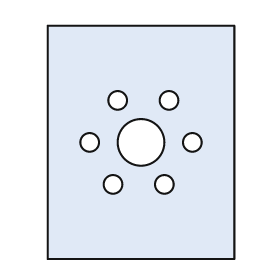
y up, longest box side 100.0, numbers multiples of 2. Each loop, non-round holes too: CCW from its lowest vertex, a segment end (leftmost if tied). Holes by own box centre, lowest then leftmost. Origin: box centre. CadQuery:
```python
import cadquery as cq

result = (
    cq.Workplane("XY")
    .moveTo(-40.0, -50.0)
    .lineTo(40.0, -50.0)
    .lineTo(40.0, 50.0)
    .lineTo(-40.0, 50.0)
    .close()
    .moveTo(-12.0, -18.0)
    .circle(4.0)
    .moveTo(10.0, -18.0)
    .circle(4.0)
    .moveTo(-22.0, 0.0)
    .circle(4.0)
    .moveTo(0.0, 0.0)
    .circle(10.0)
    .moveTo(22.0, 0.0)
    .circle(4.0)
    .moveTo(-10.0, 18.0)
    .circle(4.0)
    .moveTo(12.0, 18.0)
    .circle(4.0)
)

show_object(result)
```